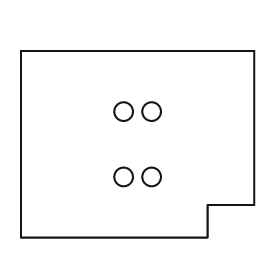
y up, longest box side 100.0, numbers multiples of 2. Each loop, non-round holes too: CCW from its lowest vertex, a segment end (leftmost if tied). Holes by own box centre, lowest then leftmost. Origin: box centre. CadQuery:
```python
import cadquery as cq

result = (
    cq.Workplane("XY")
    .moveTo(-50.0, -40.0)
    .lineTo(30.0, -40.0)
    .lineTo(30.0, -26.0)
    .lineTo(50.0, -26.0)
    .lineTo(50.0, 40.0)
    .lineTo(-50.0, 40.0)
    .close()
    .moveTo(-6.0, -14.0)
    .circle(4.0)
    .moveTo(6.0, -14.0)
    .circle(4.0)
    .moveTo(-6.0, 14.0)
    .circle(4.0)
    .moveTo(6.0, 14.0)
    .circle(4.0)
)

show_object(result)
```